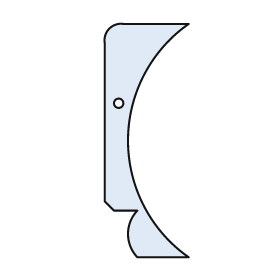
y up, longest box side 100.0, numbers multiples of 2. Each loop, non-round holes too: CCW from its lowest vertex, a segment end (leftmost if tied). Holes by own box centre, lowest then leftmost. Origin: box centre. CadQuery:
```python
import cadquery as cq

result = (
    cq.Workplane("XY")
    .moveTo(-4.0, -50.0)
    .lineTo(18.0, -50.0)
    .threePointArc((-8.0, 0.0), (18.0, 50.0))
    .lineTo(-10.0, 50.0)
    .threePointArc((-16.0, 48.0), (-18.0, 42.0))
    .lineTo(-18.0, -26.0)
    .lineTo(-14.0, -30.0)
    .lineTo(-4.0, -30.0)
    .threePointArc((-8.0, -40.0), (-4.0, -50.0))
    .close()
    .moveTo(-12.0, 16.0)
    .circle(2.0)
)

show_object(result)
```